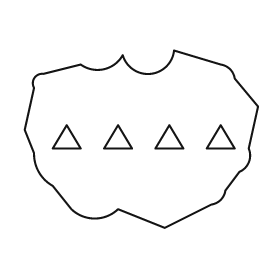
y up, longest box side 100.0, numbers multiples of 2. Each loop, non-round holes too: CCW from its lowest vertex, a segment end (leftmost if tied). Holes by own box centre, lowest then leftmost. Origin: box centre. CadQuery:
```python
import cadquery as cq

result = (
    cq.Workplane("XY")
    .moveTo(10.0, -38.0)
    .lineTo(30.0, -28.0)
    .threePointArc((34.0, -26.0), (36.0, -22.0))
    .lineTo(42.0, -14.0)
    .threePointArc((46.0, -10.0), (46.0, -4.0))
    .lineTo(50.0, 14.0)
    .lineTo(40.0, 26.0)
    .threePointArc((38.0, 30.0), (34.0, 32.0))
    .lineTo(14.0, 38.0)
    .threePointArc((4.0, 28.0), (-8.0, 36.0))
    .threePointArc((-16.0, 30.0), (-26.0, 32.0))
    .lineTo(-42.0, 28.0)
    .threePointArc((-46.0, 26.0), (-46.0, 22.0))
    .lineTo(-50.0, 4.0)
    .lineTo(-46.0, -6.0)
    .threePointArc((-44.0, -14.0), (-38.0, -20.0))
    .lineTo(-30.0, -30.0)
    .threePointArc((-20.0, -34.0), (-10.0, -30.0))
    .close()
    .moveTo(-38.0, -4.0)
    .lineTo(-26.0, -4.0)
    .lineTo(-32.0, 6.0)
    .close()
    .moveTo(-16.0, -4.0)
    .lineTo(-4.0, -4.0)
    .lineTo(-10.0, 6.0)
    .close()
    .moveTo(6.0, -4.0)
    .lineTo(18.0, -4.0)
    .lineTo(12.0, 6.0)
    .close()
    .moveTo(28.0, -4.0)
    .lineTo(40.0, -4.0)
    .lineTo(34.0, 6.0)
    .close()
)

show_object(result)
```